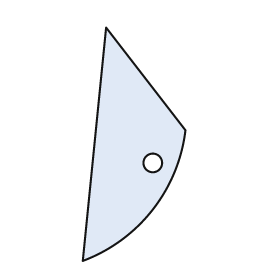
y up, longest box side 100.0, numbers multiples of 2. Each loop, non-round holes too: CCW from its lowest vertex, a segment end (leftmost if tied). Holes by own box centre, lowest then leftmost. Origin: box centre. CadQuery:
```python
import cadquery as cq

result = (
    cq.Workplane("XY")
    .moveTo(-22.0, -50.0)
    .threePointArc((8.0, -28.0), (22.0, 6.0))
    .lineTo(-12.0, 50.0)
    .close()
    .moveTo(8.0, -8.0)
    .circle(4.0)
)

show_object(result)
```